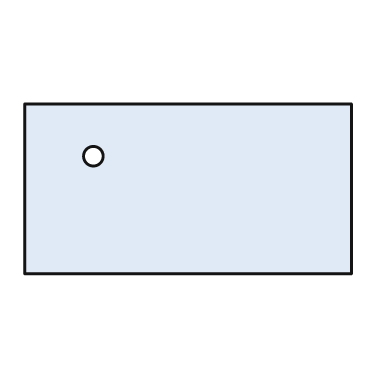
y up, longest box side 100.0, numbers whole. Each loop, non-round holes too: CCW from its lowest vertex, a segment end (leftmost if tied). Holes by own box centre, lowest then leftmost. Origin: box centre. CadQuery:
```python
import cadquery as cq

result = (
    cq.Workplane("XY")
    .moveTo(-50.0, -26.0)
    .lineTo(50.0, -26.0)
    .lineTo(50.0, 26.0)
    .lineTo(-50.0, 26.0)
    .close()
    .moveTo(-29.0, 10.0)
    .circle(3.0)
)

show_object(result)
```